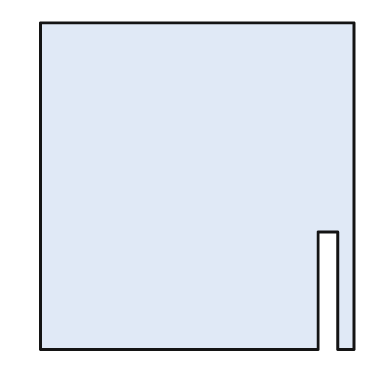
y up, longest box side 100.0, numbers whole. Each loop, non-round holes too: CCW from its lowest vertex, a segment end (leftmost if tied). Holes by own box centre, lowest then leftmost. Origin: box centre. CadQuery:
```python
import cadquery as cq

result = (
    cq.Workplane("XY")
    .moveTo(-48.0, -50.0)
    .lineTo(37.0, -50.0)
    .lineTo(37.0, -14.0)
    .lineTo(43.0, -14.0)
    .lineTo(43.0, -50.0)
    .lineTo(48.0, -50.0)
    .lineTo(48.0, 50.0)
    .lineTo(-48.0, 50.0)
    .close()
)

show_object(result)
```